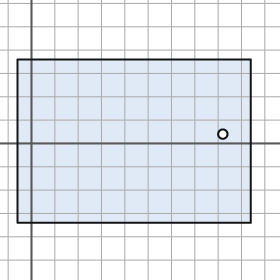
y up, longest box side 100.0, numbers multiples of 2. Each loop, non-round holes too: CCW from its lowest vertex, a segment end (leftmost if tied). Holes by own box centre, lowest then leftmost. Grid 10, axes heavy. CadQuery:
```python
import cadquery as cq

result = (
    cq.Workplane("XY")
    .moveTo(-6.0, -34.0)
    .lineTo(94.0, -34.0)
    .lineTo(94.0, 36.0)
    .lineTo(-6.0, 36.0)
    .close()
    .moveTo(82.0, 4.0)
    .circle(2.0)
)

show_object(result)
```